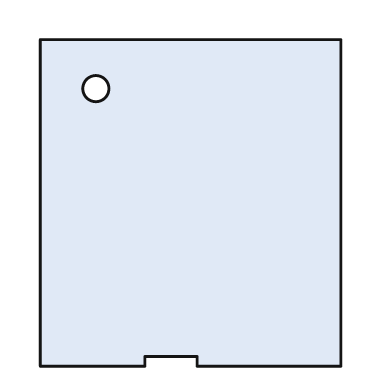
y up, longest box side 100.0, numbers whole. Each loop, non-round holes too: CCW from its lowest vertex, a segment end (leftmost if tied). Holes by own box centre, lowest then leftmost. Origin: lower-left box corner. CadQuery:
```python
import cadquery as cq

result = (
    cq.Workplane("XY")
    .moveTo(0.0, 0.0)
    .lineTo(32.0, 0.0)
    .lineTo(32.0, 3.0)
    .lineTo(48.0, 3.0)
    .lineTo(48.0, 0.0)
    .lineTo(92.0, 0.0)
    .lineTo(92.0, 100.0)
    .lineTo(0.0, 100.0)
    .close()
    .moveTo(17.0, 85.0)
    .circle(4.0)
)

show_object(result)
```